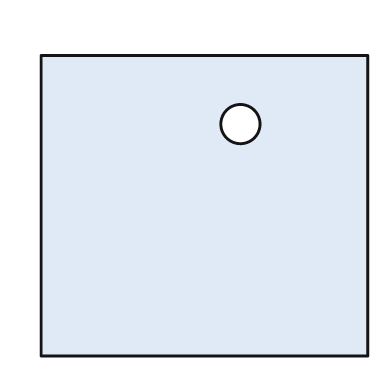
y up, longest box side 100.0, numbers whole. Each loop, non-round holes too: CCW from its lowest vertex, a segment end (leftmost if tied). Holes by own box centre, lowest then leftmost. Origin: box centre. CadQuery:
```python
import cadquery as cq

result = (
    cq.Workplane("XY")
    .moveTo(-50.0, -46.0)
    .lineTo(50.0, -46.0)
    .lineTo(50.0, 46.0)
    .lineTo(-50.0, 46.0)
    .close()
    .moveTo(11.0, 25.0)
    .circle(6.0)
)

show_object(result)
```